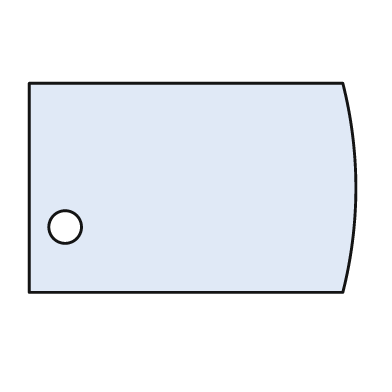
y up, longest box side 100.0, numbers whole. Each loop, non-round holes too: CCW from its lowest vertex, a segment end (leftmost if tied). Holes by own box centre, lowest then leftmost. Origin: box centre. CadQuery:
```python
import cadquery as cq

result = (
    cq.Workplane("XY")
    .moveTo(-50.0, -32.0)
    .lineTo(46.0, -32.0)
    .threePointArc((50.0, 0.0), (46.0, 32.0))
    .lineTo(-50.0, 32.0)
    .close()
    .moveTo(-39.0, -12.0)
    .circle(5.0)
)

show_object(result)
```